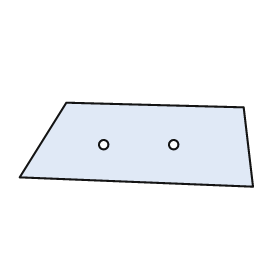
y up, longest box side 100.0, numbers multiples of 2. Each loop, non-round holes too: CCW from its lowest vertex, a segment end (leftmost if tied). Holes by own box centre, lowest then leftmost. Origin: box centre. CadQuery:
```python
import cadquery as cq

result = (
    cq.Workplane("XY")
    .moveTo(50.0, -18.0)
    .lineTo(46.0, 16.0)
    .lineTo(-30.0, 18.0)
    .lineTo(-50.0, -14.0)
    .close()
    .moveTo(-14.0, 0.0)
    .circle(2.0)
    .moveTo(16.0, 0.0)
    .circle(2.0)
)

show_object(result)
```